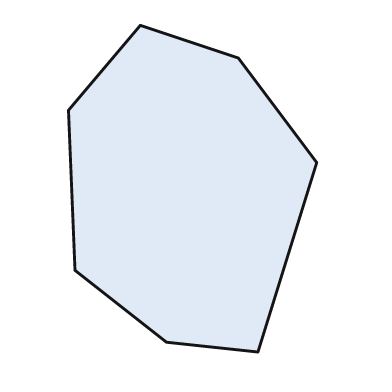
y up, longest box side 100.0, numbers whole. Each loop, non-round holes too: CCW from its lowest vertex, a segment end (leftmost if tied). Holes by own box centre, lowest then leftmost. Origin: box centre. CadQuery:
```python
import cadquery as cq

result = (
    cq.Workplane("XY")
    .moveTo(20.0, -50.0)
    .lineTo(38.0, 8.0)
    .lineTo(14.0, 40.0)
    .lineTo(-16.0, 50.0)
    .lineTo(-38.0, 24.0)
    .lineTo(-36.0, -25.0)
    .lineTo(-8.0, -47.0)
    .close()
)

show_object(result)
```